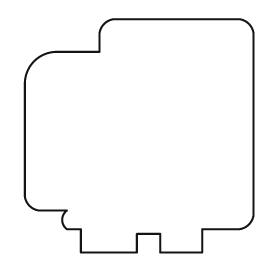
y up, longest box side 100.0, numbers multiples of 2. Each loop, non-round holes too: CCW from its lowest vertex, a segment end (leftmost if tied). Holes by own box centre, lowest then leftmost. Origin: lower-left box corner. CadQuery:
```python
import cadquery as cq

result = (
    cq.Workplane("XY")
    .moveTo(24.0, 0.0)
    .lineTo(48.0, 0.0)
    .lineTo(48.0, 8.0)
    .lineTo(58.0, 8.0)
    .lineTo(58.0, 0.0)
    .lineTo(76.0, 0.0)
    .lineTo(76.0, 10.0)
    .lineTo(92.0, 10.0)
    .threePointArc((96.0, 12.0), (98.0, 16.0))
    .lineTo(98.0, 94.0)
    .threePointArc((96.0, 98.0), (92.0, 100.0))
    .lineTo(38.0, 100.0)
    .threePointArc((34.0, 98.0), (32.0, 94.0))
    .lineTo(32.0, 86.0)
    .lineTo(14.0, 86.0)
    .threePointArc((4.0, 82.0), (0.0, 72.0))
    .lineTo(0.0, 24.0)
    .threePointArc((2.0, 20.0), (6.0, 18.0))
    .lineTo(18.0, 18.0)
    .threePointArc((16.0, 14.0), (18.0, 10.0))
    .lineTo(24.0, 10.0)
    .close()
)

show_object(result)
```